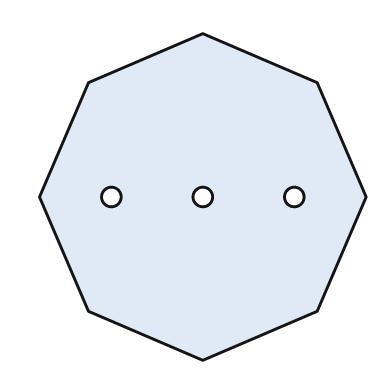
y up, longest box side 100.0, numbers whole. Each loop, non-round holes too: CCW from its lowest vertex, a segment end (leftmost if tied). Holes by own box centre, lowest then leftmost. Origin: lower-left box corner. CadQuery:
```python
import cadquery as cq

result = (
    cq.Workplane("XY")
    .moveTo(50.0, 0.0)
    .lineTo(85.0, 15.0)
    .lineTo(100.0, 50.0)
    .lineTo(85.0, 85.0)
    .lineTo(50.0, 100.0)
    .lineTo(15.0, 85.0)
    .lineTo(0.0, 50.0)
    .lineTo(15.0, 15.0)
    .close()
    .moveTo(22.0, 50.0)
    .circle(3.0)
    .moveTo(50.0, 50.0)
    .circle(3.0)
    .moveTo(78.0, 50.0)
    .circle(3.0)
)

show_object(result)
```